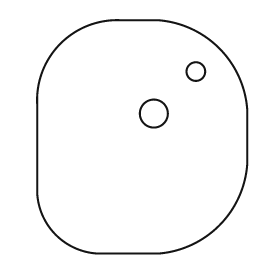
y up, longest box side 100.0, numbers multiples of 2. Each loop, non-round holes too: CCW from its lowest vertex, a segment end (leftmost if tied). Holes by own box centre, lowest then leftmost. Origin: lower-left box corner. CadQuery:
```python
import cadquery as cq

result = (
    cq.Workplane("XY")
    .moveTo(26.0, 0.0)
    .lineTo(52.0, 0.0)
    .threePointArc((78.0, 12.0), (90.0, 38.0))
    .lineTo(90.0, 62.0)
    .threePointArc((78.0, 88.0), (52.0, 100.0))
    .lineTo(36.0, 100.0)
    .threePointArc((10.0, 90.0), (0.0, 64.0))
    .lineTo(0.0, 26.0)
    .threePointArc((8.0, 8.0), (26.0, 0.0))
    .close()
    .moveTo(50.0, 60.0)
    .circle(6.0)
    .moveTo(68.0, 78.0)
    .circle(4.0)
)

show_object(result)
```